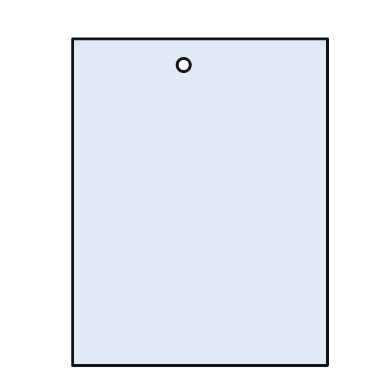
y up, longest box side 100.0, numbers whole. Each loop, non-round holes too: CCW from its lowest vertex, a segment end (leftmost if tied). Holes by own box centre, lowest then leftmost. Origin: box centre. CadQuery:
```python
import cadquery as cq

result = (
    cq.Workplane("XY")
    .moveTo(-39.0, -50.0)
    .lineTo(39.0, -50.0)
    .lineTo(39.0, 50.0)
    .lineTo(-39.0, 50.0)
    .close()
    .moveTo(-5.0, 42.0)
    .circle(2.0)
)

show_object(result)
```